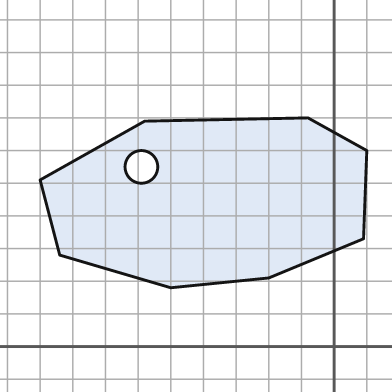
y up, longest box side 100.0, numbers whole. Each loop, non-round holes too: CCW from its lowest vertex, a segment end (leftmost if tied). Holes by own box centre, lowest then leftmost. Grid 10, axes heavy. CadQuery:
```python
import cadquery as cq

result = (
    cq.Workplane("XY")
    .moveTo(-50.0, 18.0)
    .lineTo(-20.0, 21.0)
    .lineTo(9.0, 33.0)
    .lineTo(10.0, 60.0)
    .lineTo(-8.0, 70.0)
    .lineTo(-58.0, 69.0)
    .lineTo(-90.0, 51.0)
    .lineTo(-84.0, 28.0)
    .close()
    .moveTo(-59.0, 55.0)
    .circle(5.0)
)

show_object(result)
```